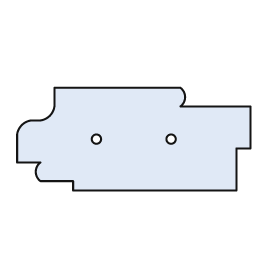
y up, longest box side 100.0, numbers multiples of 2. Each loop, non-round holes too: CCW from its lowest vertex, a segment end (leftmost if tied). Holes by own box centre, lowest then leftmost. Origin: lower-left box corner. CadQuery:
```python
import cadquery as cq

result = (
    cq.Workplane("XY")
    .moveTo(24.0, 0.0)
    .lineTo(94.0, 0.0)
    .lineTo(94.0, 18.0)
    .lineTo(100.0, 18.0)
    .lineTo(100.0, 36.0)
    .lineTo(70.0, 36.0)
    .threePointArc((72.0, 40.0), (70.0, 44.0))
    .lineTo(16.0, 44.0)
    .lineTo(16.0, 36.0)
    .threePointArc((14.0, 32.0), (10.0, 30.0))
    .lineTo(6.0, 30.0)
    .threePointArc((2.0, 28.0), (0.0, 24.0))
    .lineTo(0.0, 12.0)
    .lineTo(10.0, 12.0)
    .threePointArc((8.0, 8.0), (10.0, 4.0))
    .lineTo(24.0, 4.0)
    .close()
    .moveTo(34.0, 22.0)
    .circle(2.0)
    .moveTo(66.0, 22.0)
    .circle(2.0)
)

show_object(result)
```